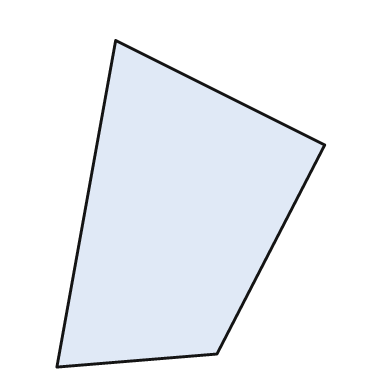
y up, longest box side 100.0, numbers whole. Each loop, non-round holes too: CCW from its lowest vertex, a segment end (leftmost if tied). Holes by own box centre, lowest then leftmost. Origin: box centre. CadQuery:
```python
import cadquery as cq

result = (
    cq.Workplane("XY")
    .moveTo(-41.0, -50.0)
    .lineTo(8.0, -46.0)
    .lineTo(41.0, 18.0)
    .lineTo(-23.0, 50.0)
    .close()
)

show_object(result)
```